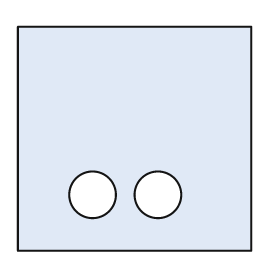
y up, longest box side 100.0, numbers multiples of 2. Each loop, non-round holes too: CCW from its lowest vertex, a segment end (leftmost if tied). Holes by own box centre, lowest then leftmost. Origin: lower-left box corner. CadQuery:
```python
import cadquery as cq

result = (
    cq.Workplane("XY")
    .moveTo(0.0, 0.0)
    .lineTo(100.0, 0.0)
    .lineTo(100.0, 96.0)
    .lineTo(0.0, 96.0)
    .close()
    .moveTo(32.0, 24.0)
    .circle(10.0)
    .moveTo(60.0, 24.0)
    .circle(10.0)
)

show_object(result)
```